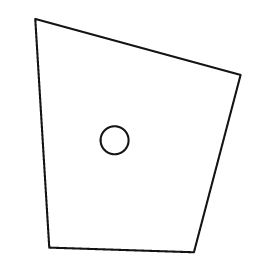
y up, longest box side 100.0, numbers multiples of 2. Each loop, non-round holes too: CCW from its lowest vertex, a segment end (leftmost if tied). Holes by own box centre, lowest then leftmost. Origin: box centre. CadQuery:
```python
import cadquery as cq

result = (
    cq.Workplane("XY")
    .moveTo(24.0, -50.0)
    .lineTo(44.0, 26.0)
    .lineTo(-44.0, 50.0)
    .lineTo(-38.0, -48.0)
    .close()
    .moveTo(-10.0, -2.0)
    .circle(6.0)
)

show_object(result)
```